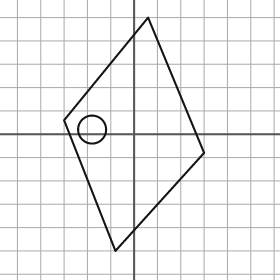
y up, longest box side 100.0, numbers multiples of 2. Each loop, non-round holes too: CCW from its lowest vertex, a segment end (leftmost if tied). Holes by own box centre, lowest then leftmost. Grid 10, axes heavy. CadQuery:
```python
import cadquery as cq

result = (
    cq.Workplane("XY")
    .moveTo(-8.0, -50.0)
    .lineTo(30.0, -8.0)
    .lineTo(6.0, 50.0)
    .lineTo(-30.0, 6.0)
    .close()
    .moveTo(-18.0, 2.0)
    .circle(6.0)
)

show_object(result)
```